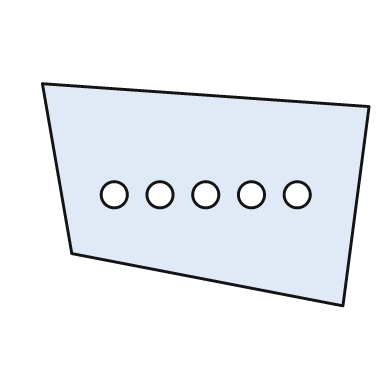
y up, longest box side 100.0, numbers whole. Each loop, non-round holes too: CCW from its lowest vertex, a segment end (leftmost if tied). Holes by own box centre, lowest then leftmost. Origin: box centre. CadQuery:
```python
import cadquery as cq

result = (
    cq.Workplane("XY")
    .moveTo(42.0, -34.0)
    .lineTo(50.0, 27.0)
    .lineTo(-50.0, 34.0)
    .lineTo(-41.0, -18.0)
    .close()
    .moveTo(-28.0, 0.0)
    .circle(4.0)
    .moveTo(-14.0, 0.0)
    .circle(4.0)
    .moveTo(0.0, 0.0)
    .circle(4.0)
    .moveTo(14.0, 0.0)
    .circle(4.0)
    .moveTo(28.0, 0.0)
    .circle(4.0)
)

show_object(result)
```